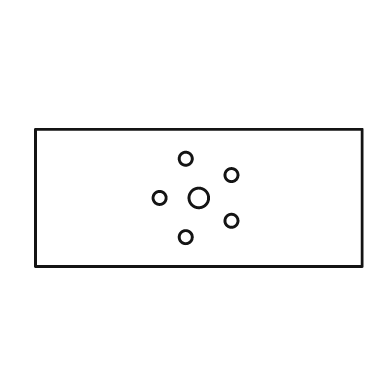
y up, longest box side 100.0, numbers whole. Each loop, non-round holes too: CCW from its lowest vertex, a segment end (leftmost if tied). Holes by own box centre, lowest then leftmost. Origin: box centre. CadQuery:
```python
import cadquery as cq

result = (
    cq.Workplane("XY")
    .moveTo(-50.0, -21.0)
    .lineTo(50.0, -21.0)
    .lineTo(50.0, 21.0)
    .lineTo(-50.0, 21.0)
    .close()
    .moveTo(-4.0, -12.0)
    .circle(2.0)
    .moveTo(10.0, -7.0)
    .circle(2.0)
    .moveTo(-12.0, 0.0)
    .circle(2.0)
    .moveTo(0.0, 0.0)
    .circle(3.0)
    .moveTo(10.0, 7.0)
    .circle(2.0)
    .moveTo(-4.0, 12.0)
    .circle(2.0)
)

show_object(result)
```